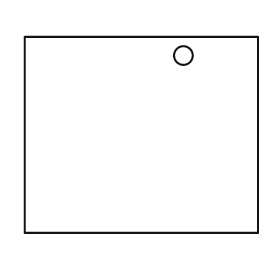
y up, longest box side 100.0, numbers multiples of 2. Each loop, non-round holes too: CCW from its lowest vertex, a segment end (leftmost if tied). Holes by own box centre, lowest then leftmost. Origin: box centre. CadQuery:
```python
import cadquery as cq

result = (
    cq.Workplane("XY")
    .moveTo(-50.0, -42.0)
    .lineTo(50.0, -42.0)
    .lineTo(50.0, 42.0)
    .lineTo(-50.0, 42.0)
    .close()
    .moveTo(18.0, 34.0)
    .circle(4.0)
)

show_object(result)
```